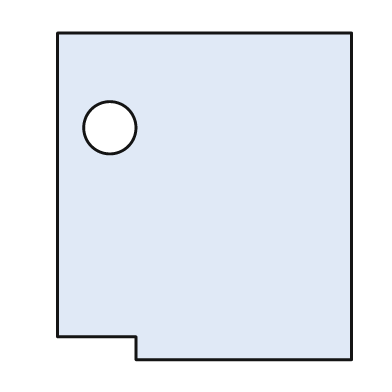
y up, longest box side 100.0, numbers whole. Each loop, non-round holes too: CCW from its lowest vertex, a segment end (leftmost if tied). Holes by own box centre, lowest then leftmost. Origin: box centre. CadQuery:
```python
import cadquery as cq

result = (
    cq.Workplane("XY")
    .moveTo(-21.0, -50.0)
    .lineTo(45.0, -50.0)
    .lineTo(45.0, 50.0)
    .lineTo(-45.0, 50.0)
    .lineTo(-45.0, -43.0)
    .lineTo(-21.0, -43.0)
    .close()
    .moveTo(-29.0, 21.0)
    .circle(8.0)
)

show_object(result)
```